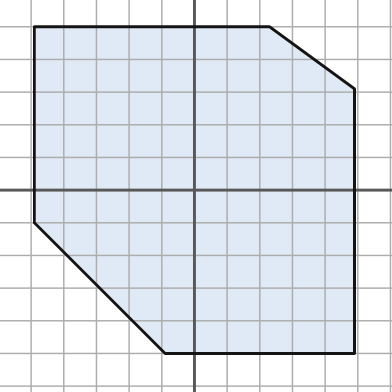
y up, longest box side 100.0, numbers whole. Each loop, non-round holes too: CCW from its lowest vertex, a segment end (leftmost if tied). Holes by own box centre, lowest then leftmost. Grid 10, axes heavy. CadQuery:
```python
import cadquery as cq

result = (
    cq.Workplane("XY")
    .moveTo(-9.0, -50.0)
    .lineTo(49.0, -50.0)
    .lineTo(49.0, 31.0)
    .lineTo(23.0, 50.0)
    .lineTo(-49.0, 50.0)
    .lineTo(-49.0, -10.0)
    .close()
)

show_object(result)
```